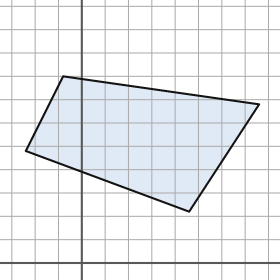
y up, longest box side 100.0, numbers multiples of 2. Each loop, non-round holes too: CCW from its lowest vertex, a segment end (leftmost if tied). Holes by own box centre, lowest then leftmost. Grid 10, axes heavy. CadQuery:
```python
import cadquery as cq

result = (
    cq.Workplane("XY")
    .moveTo(46.0, 22.0)
    .lineTo(76.0, 68.0)
    .lineTo(-8.0, 80.0)
    .lineTo(-24.0, 48.0)
    .close()
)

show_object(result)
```